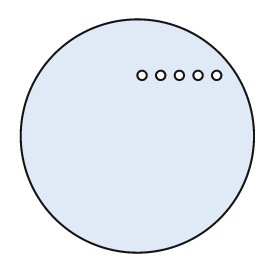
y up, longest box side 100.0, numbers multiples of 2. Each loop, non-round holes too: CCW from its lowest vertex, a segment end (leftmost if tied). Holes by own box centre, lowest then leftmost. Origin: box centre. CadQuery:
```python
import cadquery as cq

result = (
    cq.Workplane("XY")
    .moveTo(0.0, 0.0)
    .circle(50.0)
    .moveTo(2.0, 26.0)
    .circle(2.0)
    .moveTo(10.0, 26.0)
    .circle(2.0)
    .moveTo(18.0, 26.0)
    .circle(2.0)
    .moveTo(26.0, 26.0)
    .circle(2.0)
    .moveTo(34.0, 26.0)
    .circle(2.0)
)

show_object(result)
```